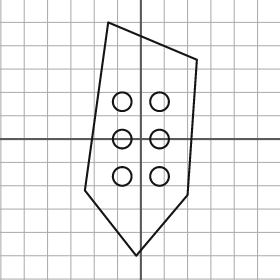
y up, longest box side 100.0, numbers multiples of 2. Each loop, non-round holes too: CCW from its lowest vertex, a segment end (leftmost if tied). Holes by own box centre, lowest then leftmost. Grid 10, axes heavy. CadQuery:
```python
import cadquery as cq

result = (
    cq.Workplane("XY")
    .moveTo(-2.0, -50.0)
    .lineTo(20.0, -24.0)
    .lineTo(24.0, 34.0)
    .lineTo(-14.0, 50.0)
    .lineTo(-24.0, -22.0)
    .close()
    .moveTo(-8.0, -16.0)
    .circle(4.0)
    .moveTo(8.0, -16.0)
    .circle(4.0)
    .moveTo(-8.0, 0.0)
    .circle(4.0)
    .moveTo(8.0, 0.0)
    .circle(4.0)
    .moveTo(-8.0, 16.0)
    .circle(4.0)
    .moveTo(8.0, 16.0)
    .circle(4.0)
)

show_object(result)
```